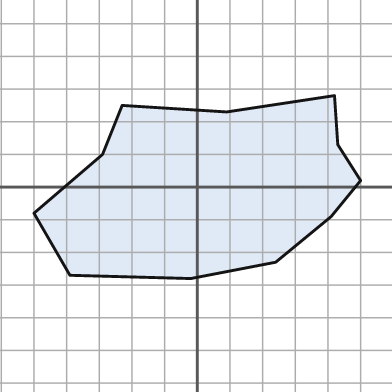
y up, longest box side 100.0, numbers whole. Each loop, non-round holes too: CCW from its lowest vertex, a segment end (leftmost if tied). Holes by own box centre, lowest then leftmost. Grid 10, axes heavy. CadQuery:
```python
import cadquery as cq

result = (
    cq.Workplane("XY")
    .moveTo(-2.0, -28.0)
    .lineTo(24.0, -23.0)
    .lineTo(41.0, -9.0)
    .lineTo(50.0, 2.0)
    .lineTo(43.0, 13.0)
    .lineTo(42.0, 28.0)
    .lineTo(9.0, 23.0)
    .lineTo(-23.0, 25.0)
    .lineTo(-29.0, 10.0)
    .lineTo(-50.0, -8.0)
    .lineTo(-39.0, -27.0)
    .close()
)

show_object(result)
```